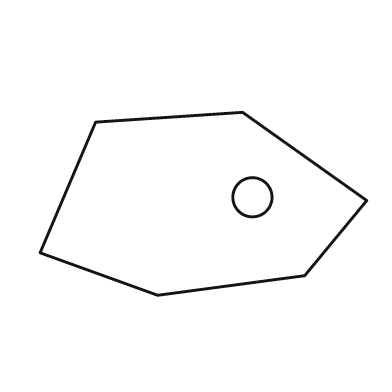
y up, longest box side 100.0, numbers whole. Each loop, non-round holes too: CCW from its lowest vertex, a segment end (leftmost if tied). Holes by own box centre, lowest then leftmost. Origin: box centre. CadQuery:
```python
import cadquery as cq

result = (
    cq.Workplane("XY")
    .moveTo(-14.0, -28.0)
    .lineTo(31.0, -22.0)
    .lineTo(50.0, 1.0)
    .lineTo(12.0, 28.0)
    .lineTo(-33.0, 25.0)
    .lineTo(-50.0, -15.0)
    .close()
    .moveTo(15.0, 2.0)
    .circle(6.0)
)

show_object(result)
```